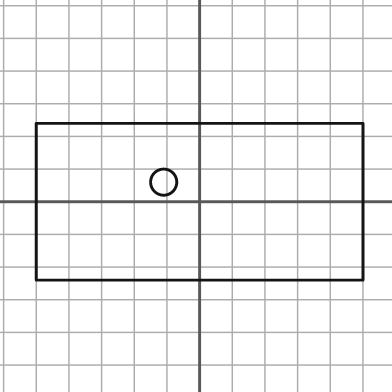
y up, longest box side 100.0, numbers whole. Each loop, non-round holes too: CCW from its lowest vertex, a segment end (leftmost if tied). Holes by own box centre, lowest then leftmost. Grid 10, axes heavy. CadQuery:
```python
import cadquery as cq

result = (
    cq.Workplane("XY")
    .moveTo(-50.0, -24.0)
    .lineTo(50.0, -24.0)
    .lineTo(50.0, 24.0)
    .lineTo(-50.0, 24.0)
    .close()
    .moveTo(-11.0, 6.0)
    .circle(4.0)
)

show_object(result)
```